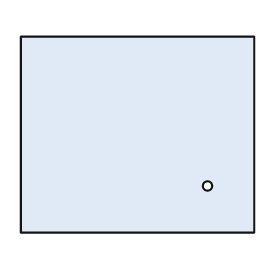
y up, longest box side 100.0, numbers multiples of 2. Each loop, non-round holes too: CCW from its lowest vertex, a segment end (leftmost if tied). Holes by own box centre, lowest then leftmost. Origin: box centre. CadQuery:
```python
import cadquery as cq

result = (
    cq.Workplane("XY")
    .moveTo(-50.0, -42.0)
    .lineTo(50.0, -42.0)
    .lineTo(50.0, 42.0)
    .lineTo(-50.0, 42.0)
    .close()
    .moveTo(30.0, -22.0)
    .circle(2.0)
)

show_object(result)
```